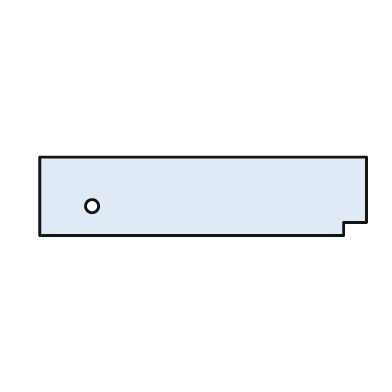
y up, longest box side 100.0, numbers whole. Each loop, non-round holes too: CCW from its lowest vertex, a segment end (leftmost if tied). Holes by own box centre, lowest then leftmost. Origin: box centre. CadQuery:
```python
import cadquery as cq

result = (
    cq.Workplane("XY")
    .moveTo(-50.0, -12.0)
    .lineTo(43.0, -12.0)
    .lineTo(43.0, -8.0)
    .lineTo(50.0, -8.0)
    .lineTo(50.0, 12.0)
    .lineTo(-50.0, 12.0)
    .close()
    .moveTo(-34.0, -3.0)
    .circle(2.0)
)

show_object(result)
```